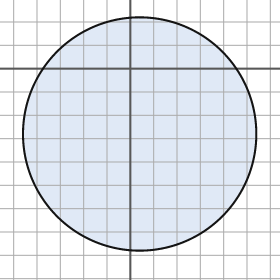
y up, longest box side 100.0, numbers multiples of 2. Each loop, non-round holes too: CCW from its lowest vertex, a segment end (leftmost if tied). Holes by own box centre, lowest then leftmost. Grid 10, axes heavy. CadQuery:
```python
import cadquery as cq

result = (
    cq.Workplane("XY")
    .moveTo(4.0, -28.0)
    .circle(50.0)
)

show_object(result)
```